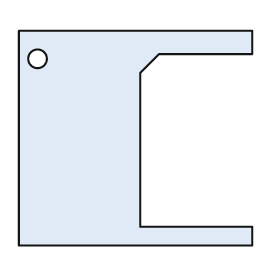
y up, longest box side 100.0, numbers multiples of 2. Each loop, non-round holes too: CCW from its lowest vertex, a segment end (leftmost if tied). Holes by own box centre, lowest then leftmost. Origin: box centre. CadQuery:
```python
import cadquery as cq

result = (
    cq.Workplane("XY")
    .moveTo(-50.0, -46.0)
    .lineTo(50.0, -46.0)
    .lineTo(50.0, -38.0)
    .lineTo(2.0, -38.0)
    .lineTo(2.0, 28.0)
    .lineTo(10.0, 36.0)
    .lineTo(50.0, 36.0)
    .lineTo(50.0, 46.0)
    .lineTo(-50.0, 46.0)
    .close()
    .moveTo(-42.0, 34.0)
    .circle(4.0)
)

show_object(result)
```